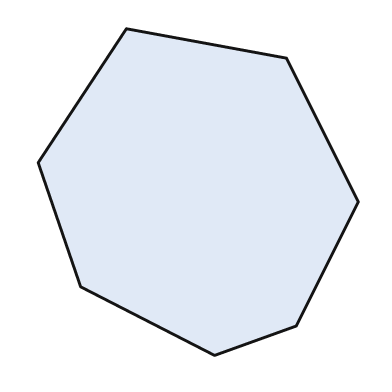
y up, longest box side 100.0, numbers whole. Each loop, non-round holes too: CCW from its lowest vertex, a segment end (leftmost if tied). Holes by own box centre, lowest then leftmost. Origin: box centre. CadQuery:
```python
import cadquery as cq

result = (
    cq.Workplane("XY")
    .moveTo(5.0, -50.0)
    .lineTo(30.0, -41.0)
    .lineTo(49.0, -3.0)
    .lineTo(27.0, 41.0)
    .lineTo(-22.0, 50.0)
    .lineTo(-49.0, 9.0)
    .lineTo(-36.0, -29.0)
    .close()
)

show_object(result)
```